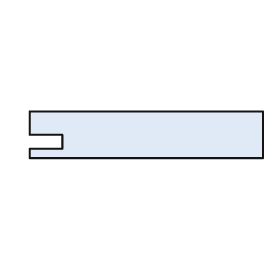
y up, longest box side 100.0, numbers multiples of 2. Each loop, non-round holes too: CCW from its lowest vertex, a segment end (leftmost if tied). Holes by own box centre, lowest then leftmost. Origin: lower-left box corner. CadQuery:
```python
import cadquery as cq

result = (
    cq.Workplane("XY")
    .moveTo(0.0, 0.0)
    .lineTo(100.0, 0.0)
    .lineTo(100.0, 20.0)
    .lineTo(0.0, 20.0)
    .lineTo(0.0, 10.0)
    .lineTo(14.0, 10.0)
    .lineTo(14.0, 4.0)
    .lineTo(0.0, 4.0)
    .close()
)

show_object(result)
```